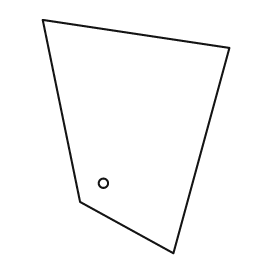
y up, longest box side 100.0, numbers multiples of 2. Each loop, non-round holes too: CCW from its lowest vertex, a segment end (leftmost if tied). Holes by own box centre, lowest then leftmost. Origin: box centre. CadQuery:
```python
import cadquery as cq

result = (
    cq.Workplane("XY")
    .moveTo(16.0, -50.0)
    .lineTo(40.0, 38.0)
    .lineTo(-40.0, 50.0)
    .lineTo(-24.0, -28.0)
    .close()
    .moveTo(-14.0, -20.0)
    .circle(2.0)
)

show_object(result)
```